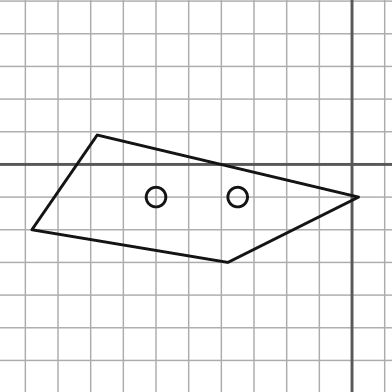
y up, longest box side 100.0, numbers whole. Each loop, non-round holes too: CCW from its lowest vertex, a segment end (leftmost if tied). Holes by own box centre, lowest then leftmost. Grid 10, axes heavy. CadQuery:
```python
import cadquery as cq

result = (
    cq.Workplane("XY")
    .moveTo(-38.0, -30.0)
    .lineTo(2.0, -10.0)
    .lineTo(-78.0, 9.0)
    .lineTo(-98.0, -20.0)
    .close()
    .moveTo(-60.0, -10.0)
    .circle(3.0)
    .moveTo(-35.0, -10.0)
    .circle(3.0)
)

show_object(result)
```